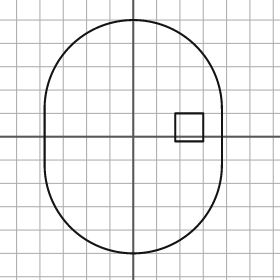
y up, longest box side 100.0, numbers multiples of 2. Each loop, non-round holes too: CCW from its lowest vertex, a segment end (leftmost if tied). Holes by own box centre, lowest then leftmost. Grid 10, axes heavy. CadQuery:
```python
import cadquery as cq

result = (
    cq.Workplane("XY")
    .moveTo(-38.0, -12.0)
    .threePointArc((0.0, -50.0), (38.0, -12.0))
    .lineTo(38.0, 12.0)
    .threePointArc((0.0, 50.0), (-38.0, 12.0))
    .close()
    .moveTo(18.0, -2.0)
    .lineTo(30.0, -2.0)
    .lineTo(30.0, 10.0)
    .lineTo(18.0, 10.0)
    .close()
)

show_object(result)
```